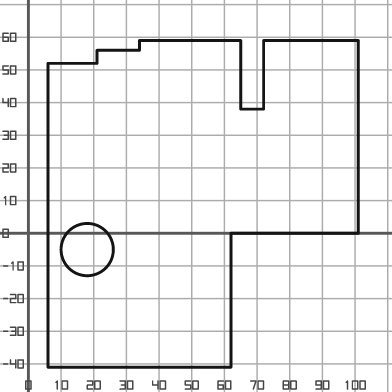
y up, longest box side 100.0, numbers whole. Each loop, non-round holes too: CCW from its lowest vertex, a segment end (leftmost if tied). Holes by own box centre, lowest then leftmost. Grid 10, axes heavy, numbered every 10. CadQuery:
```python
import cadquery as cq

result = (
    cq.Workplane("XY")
    .moveTo(6.0, -41.0)
    .lineTo(62.0, -41.0)
    .lineTo(62.0, 0.0)
    .lineTo(101.0, 0.0)
    .lineTo(101.0, 59.0)
    .lineTo(72.0, 59.0)
    .lineTo(72.0, 38.0)
    .lineTo(65.0, 38.0)
    .lineTo(65.0, 59.0)
    .lineTo(34.0, 59.0)
    .lineTo(34.0, 56.0)
    .lineTo(21.0, 56.0)
    .lineTo(21.0, 52.0)
    .lineTo(6.0, 52.0)
    .close()
    .moveTo(18.0, -5.0)
    .circle(8.0)
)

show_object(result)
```